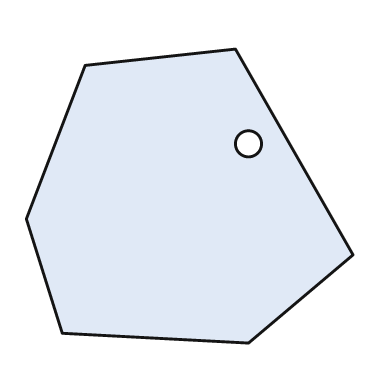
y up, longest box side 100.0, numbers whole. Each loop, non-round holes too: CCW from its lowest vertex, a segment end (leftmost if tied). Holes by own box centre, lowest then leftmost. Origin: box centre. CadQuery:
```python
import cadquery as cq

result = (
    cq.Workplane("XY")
    .moveTo(18.0, -45.0)
    .lineTo(50.0, -18.0)
    .lineTo(14.0, 45.0)
    .lineTo(-32.0, 40.0)
    .lineTo(-50.0, -7.0)
    .lineTo(-39.0, -42.0)
    .close()
    .moveTo(18.0, 16.0)
    .circle(4.0)
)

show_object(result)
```